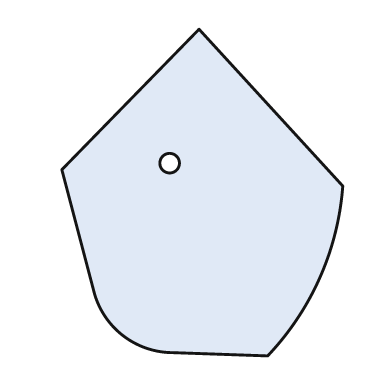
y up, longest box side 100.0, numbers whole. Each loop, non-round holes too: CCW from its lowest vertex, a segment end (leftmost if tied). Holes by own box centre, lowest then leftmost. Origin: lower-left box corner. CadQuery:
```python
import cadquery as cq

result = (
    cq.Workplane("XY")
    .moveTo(63.0, 0.0)
    .threePointArc((79.0, 24.0), (86.0, 52.0))
    .lineTo(42.0, 100.0)
    .lineTo(0.0, 57.0)
    .lineTo(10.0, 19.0)
    .threePointArc((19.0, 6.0), (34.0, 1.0))
    .close()
    .moveTo(33.0, 59.0)
    .circle(3.0)
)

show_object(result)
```